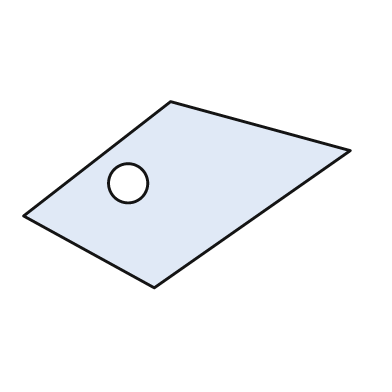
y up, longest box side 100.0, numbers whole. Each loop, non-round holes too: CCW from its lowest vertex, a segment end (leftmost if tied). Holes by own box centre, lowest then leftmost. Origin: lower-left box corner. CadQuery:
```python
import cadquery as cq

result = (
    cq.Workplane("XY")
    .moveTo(40.0, 0.0)
    .lineTo(100.0, 42.0)
    .lineTo(45.0, 57.0)
    .lineTo(0.0, 22.0)
    .close()
    .moveTo(32.0, 32.0)
    .circle(6.0)
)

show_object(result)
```